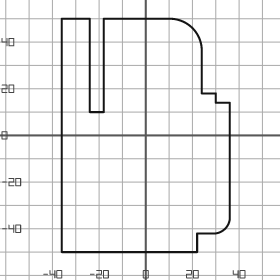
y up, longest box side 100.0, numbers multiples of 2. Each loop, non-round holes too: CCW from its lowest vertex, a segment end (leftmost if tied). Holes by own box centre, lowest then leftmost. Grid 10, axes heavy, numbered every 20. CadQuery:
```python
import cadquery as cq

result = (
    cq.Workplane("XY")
    .moveTo(-36.0, -50.0)
    .lineTo(22.0, -50.0)
    .lineTo(22.0, -42.0)
    .lineTo(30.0, -42.0)
    .threePointArc((34.0, -40.0), (36.0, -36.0))
    .lineTo(36.0, 14.0)
    .lineTo(30.0, 14.0)
    .lineTo(30.0, 18.0)
    .lineTo(24.0, 18.0)
    .lineTo(24.0, 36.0)
    .threePointArc((20.0, 46.0), (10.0, 50.0))
    .lineTo(-18.0, 50.0)
    .lineTo(-18.0, 10.0)
    .lineTo(-24.0, 10.0)
    .lineTo(-24.0, 50.0)
    .lineTo(-36.0, 50.0)
    .close()
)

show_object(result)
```